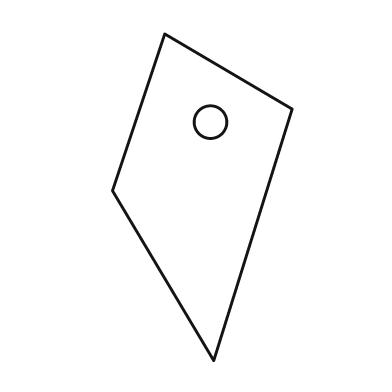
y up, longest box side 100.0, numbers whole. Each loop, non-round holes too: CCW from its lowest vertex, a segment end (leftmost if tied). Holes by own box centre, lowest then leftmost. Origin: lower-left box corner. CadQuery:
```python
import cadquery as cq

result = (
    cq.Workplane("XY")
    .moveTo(31.0, 0.0)
    .lineTo(55.0, 77.0)
    .lineTo(16.0, 100.0)
    .lineTo(0.0, 52.0)
    .close()
    .moveTo(30.0, 73.0)
    .circle(5.0)
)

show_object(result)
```